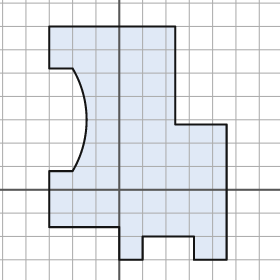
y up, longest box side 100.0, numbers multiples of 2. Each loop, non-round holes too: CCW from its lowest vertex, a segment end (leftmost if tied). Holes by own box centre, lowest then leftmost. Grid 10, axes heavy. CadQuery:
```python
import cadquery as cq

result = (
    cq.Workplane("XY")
    .moveTo(0.0, -30.0)
    .lineTo(10.0, -30.0)
    .lineTo(10.0, -20.0)
    .lineTo(32.0, -20.0)
    .lineTo(32.0, -30.0)
    .lineTo(46.0, -30.0)
    .lineTo(46.0, 28.0)
    .lineTo(24.0, 28.0)
    .lineTo(24.0, 70.0)
    .lineTo(-30.0, 70.0)
    .lineTo(-30.0, 52.0)
    .lineTo(-20.0, 52.0)
    .threePointArc((-14.0, 30.0), (-20.0, 8.0))
    .lineTo(-30.0, 8.0)
    .lineTo(-30.0, -16.0)
    .lineTo(0.0, -16.0)
    .close()
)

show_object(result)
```